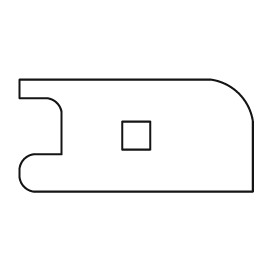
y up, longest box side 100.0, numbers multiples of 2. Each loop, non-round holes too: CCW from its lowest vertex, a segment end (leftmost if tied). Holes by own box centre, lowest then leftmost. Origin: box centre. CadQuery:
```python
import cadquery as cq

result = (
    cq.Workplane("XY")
    .moveTo(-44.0, -24.0)
    .lineTo(50.0, -24.0)
    .lineTo(50.0, 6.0)
    .threePointArc((44.0, 18.0), (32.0, 24.0))
    .lineTo(-50.0, 24.0)
    .lineTo(-50.0, 16.0)
    .lineTo(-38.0, 16.0)
    .threePointArc((-34.0, 14.0), (-32.0, 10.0))
    .lineTo(-32.0, -8.0)
    .lineTo(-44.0, -8.0)
    .threePointArc((-48.0, -10.0), (-50.0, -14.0))
    .lineTo(-50.0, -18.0)
    .threePointArc((-48.0, -22.0), (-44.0, -24.0))
    .close()
    .moveTo(-6.0, -6.0)
    .lineTo(6.0, -6.0)
    .lineTo(6.0, 6.0)
    .lineTo(-6.0, 6.0)
    .close()
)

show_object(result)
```